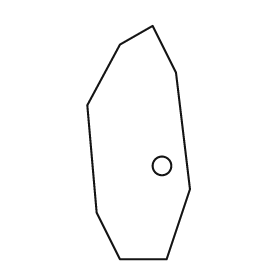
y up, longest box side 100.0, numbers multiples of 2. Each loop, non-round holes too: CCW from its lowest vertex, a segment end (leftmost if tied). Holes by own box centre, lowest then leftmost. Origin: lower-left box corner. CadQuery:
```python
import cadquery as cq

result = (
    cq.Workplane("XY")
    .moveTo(14.0, 0.0)
    .lineTo(34.0, 0.0)
    .lineTo(44.0, 30.0)
    .lineTo(38.0, 80.0)
    .lineTo(28.0, 100.0)
    .lineTo(14.0, 92.0)
    .lineTo(0.0, 66.0)
    .lineTo(4.0, 20.0)
    .close()
    .moveTo(32.0, 40.0)
    .circle(4.0)
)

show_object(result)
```